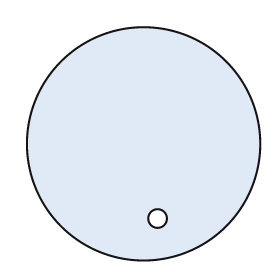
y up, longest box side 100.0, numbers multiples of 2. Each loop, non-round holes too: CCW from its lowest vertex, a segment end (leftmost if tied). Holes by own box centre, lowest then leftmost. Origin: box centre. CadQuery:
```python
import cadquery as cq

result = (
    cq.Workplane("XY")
    .moveTo(0.0, 0.0)
    .circle(50.0)
    .moveTo(6.0, -32.0)
    .circle(4.0)
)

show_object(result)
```